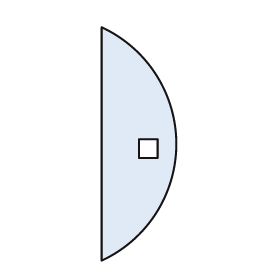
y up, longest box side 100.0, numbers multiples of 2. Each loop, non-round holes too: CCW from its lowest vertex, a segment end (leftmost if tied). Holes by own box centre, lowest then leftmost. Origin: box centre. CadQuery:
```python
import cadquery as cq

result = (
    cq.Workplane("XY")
    .moveTo(-16.0, -50.0)
    .threePointArc((16.0, 0.0), (-16.0, 50.0))
    .close()
    .moveTo(0.0, -6.0)
    .lineTo(8.0, -6.0)
    .lineTo(8.0, 2.0)
    .lineTo(0.0, 2.0)
    .close()
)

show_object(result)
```